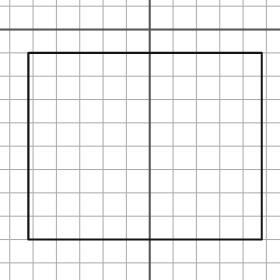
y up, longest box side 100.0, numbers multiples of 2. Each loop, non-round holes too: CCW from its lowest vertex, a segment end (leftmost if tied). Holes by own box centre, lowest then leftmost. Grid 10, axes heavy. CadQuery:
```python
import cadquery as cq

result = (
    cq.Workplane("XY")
    .moveTo(-52.0, -90.0)
    .lineTo(48.0, -90.0)
    .lineTo(48.0, -10.0)
    .lineTo(-52.0, -10.0)
    .close()
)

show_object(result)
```